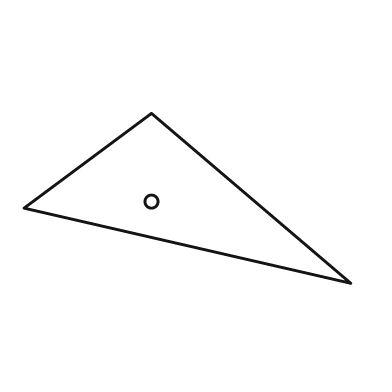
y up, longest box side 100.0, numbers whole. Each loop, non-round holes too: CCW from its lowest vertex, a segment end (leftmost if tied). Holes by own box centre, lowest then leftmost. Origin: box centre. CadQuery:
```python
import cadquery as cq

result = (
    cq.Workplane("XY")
    .moveTo(50.0, -26.0)
    .lineTo(-11.0, 26.0)
    .lineTo(-50.0, -3.0)
    .close()
    .moveTo(-11.0, -1.0)
    .circle(2.0)
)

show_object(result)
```